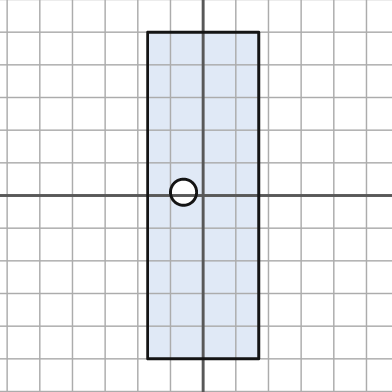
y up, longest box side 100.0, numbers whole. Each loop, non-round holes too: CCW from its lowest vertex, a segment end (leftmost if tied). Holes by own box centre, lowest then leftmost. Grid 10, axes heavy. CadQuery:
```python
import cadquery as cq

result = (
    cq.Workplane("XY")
    .moveTo(-17.0, -50.0)
    .lineTo(17.0, -50.0)
    .lineTo(17.0, 50.0)
    .lineTo(-17.0, 50.0)
    .close()
    .moveTo(-6.0, 1.0)
    .circle(4.0)
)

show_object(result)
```